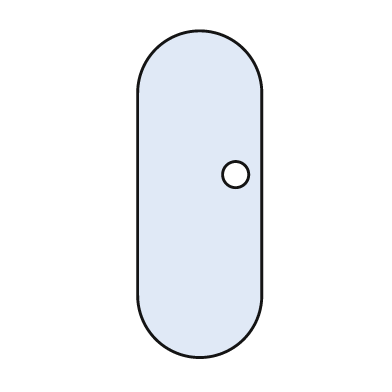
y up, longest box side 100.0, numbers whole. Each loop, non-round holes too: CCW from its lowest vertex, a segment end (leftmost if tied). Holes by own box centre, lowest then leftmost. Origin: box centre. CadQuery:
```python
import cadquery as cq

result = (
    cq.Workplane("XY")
    .moveTo(-19.0, -31.0)
    .threePointArc((0.0, -50.0), (19.0, -31.0))
    .lineTo(19.0, 31.0)
    .threePointArc((0.0, 50.0), (-19.0, 31.0))
    .close()
    .moveTo(11.0, 6.0)
    .circle(4.0)
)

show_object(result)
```